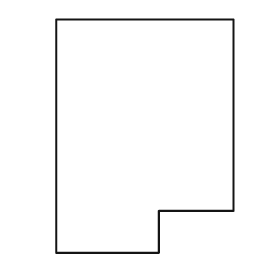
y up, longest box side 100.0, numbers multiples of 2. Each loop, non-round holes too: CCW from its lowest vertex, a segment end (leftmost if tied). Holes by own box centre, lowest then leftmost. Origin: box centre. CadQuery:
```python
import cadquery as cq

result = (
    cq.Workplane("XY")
    .moveTo(-38.0, -50.0)
    .lineTo(6.0, -50.0)
    .lineTo(6.0, -32.0)
    .lineTo(38.0, -32.0)
    .lineTo(38.0, 50.0)
    .lineTo(-38.0, 50.0)
    .close()
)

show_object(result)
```